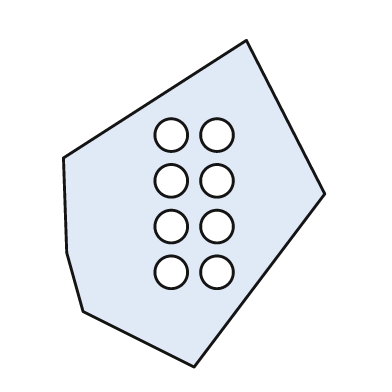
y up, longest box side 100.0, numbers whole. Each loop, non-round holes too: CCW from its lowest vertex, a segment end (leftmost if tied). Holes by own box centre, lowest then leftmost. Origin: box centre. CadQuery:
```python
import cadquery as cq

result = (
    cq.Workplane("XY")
    .moveTo(0.0, -50.0)
    .lineTo(40.0, 3.0)
    .lineTo(16.0, 50.0)
    .lineTo(-40.0, 14.0)
    .lineTo(-39.0, -15.0)
    .lineTo(-34.0, -33.0)
    .close()
    .moveTo(-7.0, -21.0)
    .circle(5.0)
    .moveTo(7.0, -21.0)
    .circle(5.0)
    .moveTo(-7.0, -7.0)
    .circle(5.0)
    .moveTo(7.0, -7.0)
    .circle(5.0)
    .moveTo(-7.0, 7.0)
    .circle(5.0)
    .moveTo(7.0, 7.0)
    .circle(5.0)
    .moveTo(-7.0, 21.0)
    .circle(5.0)
    .moveTo(7.0, 21.0)
    .circle(5.0)
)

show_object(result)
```